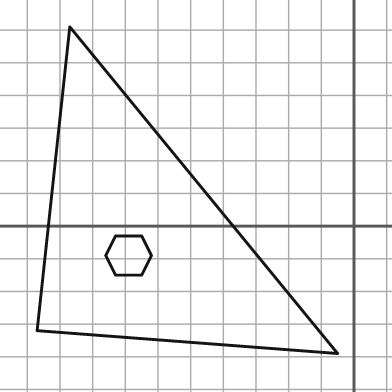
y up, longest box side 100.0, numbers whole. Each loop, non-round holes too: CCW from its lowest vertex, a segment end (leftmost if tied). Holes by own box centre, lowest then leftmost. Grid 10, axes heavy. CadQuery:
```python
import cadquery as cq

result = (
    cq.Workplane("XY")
    .moveTo(-5.0, -39.0)
    .lineTo(-87.0, 61.0)
    .lineTo(-97.0, -32.0)
    .close()
    .moveTo(-73.0, -15.0)
    .lineTo(-65.0, -15.0)
    .lineTo(-62.0, -9.0)
    .lineTo(-65.0, -3.0)
    .lineTo(-73.0, -3.0)
    .lineTo(-76.0, -9.0)
    .close()
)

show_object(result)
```